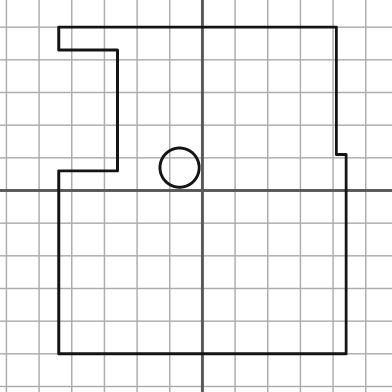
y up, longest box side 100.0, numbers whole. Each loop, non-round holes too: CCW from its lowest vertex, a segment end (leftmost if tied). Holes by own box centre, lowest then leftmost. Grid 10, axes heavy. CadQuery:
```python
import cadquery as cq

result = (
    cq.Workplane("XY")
    .moveTo(-44.0, -50.0)
    .lineTo(44.0, -50.0)
    .lineTo(44.0, 11.0)
    .lineTo(41.0, 11.0)
    .lineTo(41.0, 50.0)
    .lineTo(-44.0, 50.0)
    .lineTo(-44.0, 43.0)
    .lineTo(-26.0, 43.0)
    .lineTo(-26.0, 6.0)
    .lineTo(-44.0, 6.0)
    .close()
    .moveTo(-7.0, 7.0)
    .circle(6.0)
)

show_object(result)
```